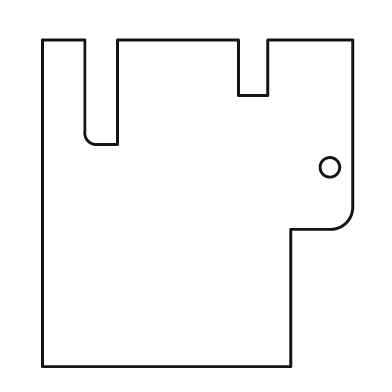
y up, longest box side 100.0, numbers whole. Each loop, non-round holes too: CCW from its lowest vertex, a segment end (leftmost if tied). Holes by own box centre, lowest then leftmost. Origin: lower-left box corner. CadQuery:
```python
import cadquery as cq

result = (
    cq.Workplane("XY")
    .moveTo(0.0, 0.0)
    .lineTo(76.0, 0.0)
    .lineTo(76.0, 42.0)
    .lineTo(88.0, 42.0)
    .threePointArc((93.0, 44.0), (95.0, 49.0))
    .lineTo(95.0, 100.0)
    .lineTo(69.0, 100.0)
    .lineTo(69.0, 83.0)
    .lineTo(60.0, 83.0)
    .lineTo(60.0, 100.0)
    .lineTo(23.0, 100.0)
    .lineTo(23.0, 68.0)
    .lineTo(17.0, 68.0)
    .threePointArc((14.0, 69.0), (13.0, 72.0))
    .lineTo(13.0, 100.0)
    .lineTo(0.0, 100.0)
    .close()
    .moveTo(88.0, 61.0)
    .circle(3.0)
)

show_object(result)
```